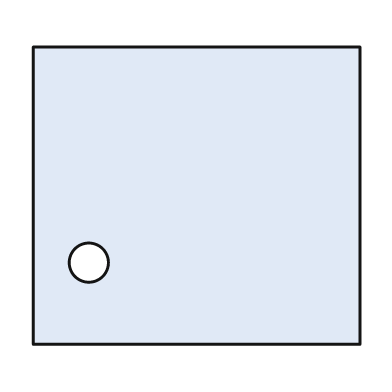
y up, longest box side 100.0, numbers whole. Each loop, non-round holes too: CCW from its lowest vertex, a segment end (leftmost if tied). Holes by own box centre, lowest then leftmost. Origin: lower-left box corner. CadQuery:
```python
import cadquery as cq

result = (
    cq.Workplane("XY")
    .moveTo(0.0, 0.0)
    .lineTo(100.0, 0.0)
    .lineTo(100.0, 91.0)
    .lineTo(0.0, 91.0)
    .close()
    .moveTo(17.0, 25.0)
    .circle(6.0)
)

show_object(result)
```